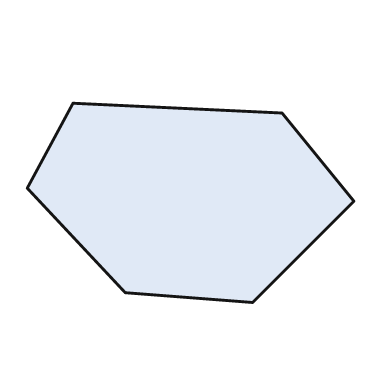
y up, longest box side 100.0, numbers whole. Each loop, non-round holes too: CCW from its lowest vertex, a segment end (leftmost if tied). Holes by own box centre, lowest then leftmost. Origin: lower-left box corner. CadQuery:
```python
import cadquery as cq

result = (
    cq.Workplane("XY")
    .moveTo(69.0, 0.0)
    .lineTo(100.0, 31.0)
    .lineTo(78.0, 58.0)
    .lineTo(14.0, 61.0)
    .lineTo(0.0, 35.0)
    .lineTo(30.0, 3.0)
    .close()
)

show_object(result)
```